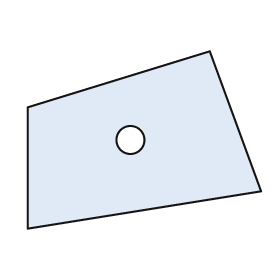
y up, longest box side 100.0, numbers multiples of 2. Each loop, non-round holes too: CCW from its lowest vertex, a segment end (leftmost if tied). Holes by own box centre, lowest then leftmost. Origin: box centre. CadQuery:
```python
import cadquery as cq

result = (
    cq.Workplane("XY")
    .moveTo(-50.0, -38.0)
    .lineTo(50.0, -22.0)
    .lineTo(28.0, 38.0)
    .lineTo(-50.0, 14.0)
    .close()
    .moveTo(-6.0, 0.0)
    .circle(6.0)
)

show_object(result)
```